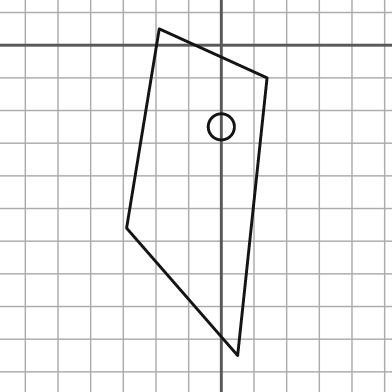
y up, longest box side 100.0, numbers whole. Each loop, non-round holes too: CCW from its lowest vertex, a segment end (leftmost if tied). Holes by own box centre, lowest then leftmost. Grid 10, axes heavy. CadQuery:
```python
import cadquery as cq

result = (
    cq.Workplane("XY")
    .moveTo(5.0, -95.0)
    .lineTo(14.0, -10.0)
    .lineTo(-19.0, 5.0)
    .lineTo(-29.0, -56.0)
    .close()
    .moveTo(0.0, -25.0)
    .circle(4.0)
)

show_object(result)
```